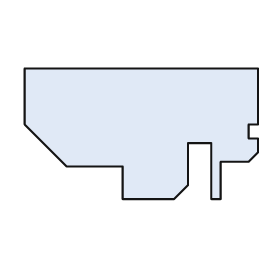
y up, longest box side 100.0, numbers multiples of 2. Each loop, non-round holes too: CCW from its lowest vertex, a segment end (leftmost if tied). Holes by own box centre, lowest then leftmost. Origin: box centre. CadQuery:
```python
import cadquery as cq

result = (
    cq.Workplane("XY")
    .moveTo(-8.0, -28.0)
    .lineTo(14.0, -28.0)
    .lineTo(20.0, -22.0)
    .lineTo(20.0, -4.0)
    .lineTo(30.0, -4.0)
    .lineTo(30.0, -28.0)
    .lineTo(34.0, -28.0)
    .lineTo(34.0, -12.0)
    .lineTo(46.0, -12.0)
    .lineTo(50.0, -8.0)
    .lineTo(50.0, -2.0)
    .lineTo(46.0, -2.0)
    .lineTo(46.0, 4.0)
    .lineTo(50.0, 4.0)
    .lineTo(50.0, 28.0)
    .lineTo(-50.0, 28.0)
    .lineTo(-50.0, 4.0)
    .lineTo(-32.0, -14.0)
    .lineTo(-8.0, -14.0)
    .close()
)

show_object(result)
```